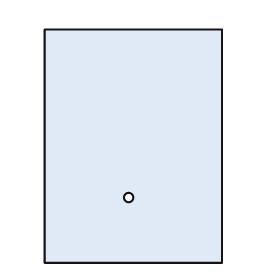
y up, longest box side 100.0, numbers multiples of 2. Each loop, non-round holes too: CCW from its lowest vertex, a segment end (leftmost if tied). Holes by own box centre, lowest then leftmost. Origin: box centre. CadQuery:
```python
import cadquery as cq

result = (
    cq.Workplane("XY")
    .moveTo(-38.0, -50.0)
    .lineTo(38.0, -50.0)
    .lineTo(38.0, 50.0)
    .lineTo(-38.0, 50.0)
    .close()
    .moveTo(-2.0, -22.0)
    .circle(2.0)
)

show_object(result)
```